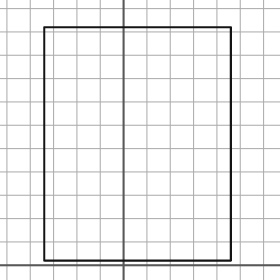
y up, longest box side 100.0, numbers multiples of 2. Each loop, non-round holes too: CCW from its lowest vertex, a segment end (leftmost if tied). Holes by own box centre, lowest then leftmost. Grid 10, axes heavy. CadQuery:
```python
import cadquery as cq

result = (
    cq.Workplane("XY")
    .moveTo(-34.0, 2.0)
    .lineTo(46.0, 2.0)
    .lineTo(46.0, 102.0)
    .lineTo(-34.0, 102.0)
    .close()
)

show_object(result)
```